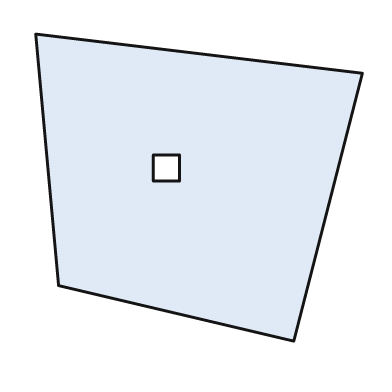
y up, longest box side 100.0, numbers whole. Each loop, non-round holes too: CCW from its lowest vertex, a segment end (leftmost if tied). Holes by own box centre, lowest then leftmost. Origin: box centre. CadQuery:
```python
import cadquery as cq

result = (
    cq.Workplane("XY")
    .moveTo(29.0, -47.0)
    .lineTo(50.0, 35.0)
    .lineTo(-50.0, 47.0)
    .lineTo(-43.0, -30.0)
    .close()
    .moveTo(-14.0, 2.0)
    .lineTo(-6.0, 2.0)
    .lineTo(-6.0, 10.0)
    .lineTo(-14.0, 10.0)
    .close()
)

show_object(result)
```